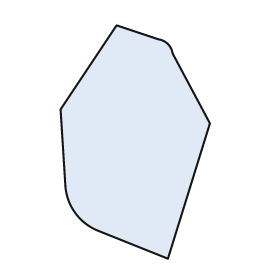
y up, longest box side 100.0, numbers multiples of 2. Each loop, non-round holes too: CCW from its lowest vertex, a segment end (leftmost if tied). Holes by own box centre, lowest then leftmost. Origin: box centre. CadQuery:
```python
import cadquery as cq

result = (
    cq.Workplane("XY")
    .moveTo(14.0, -50.0)
    .lineTo(32.0, 8.0)
    .lineTo(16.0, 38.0)
    .threePointArc((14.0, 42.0), (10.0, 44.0))
    .lineTo(-8.0, 50.0)
    .lineTo(-32.0, 14.0)
    .lineTo(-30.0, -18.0)
    .threePointArc((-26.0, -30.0), (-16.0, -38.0))
    .close()
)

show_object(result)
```